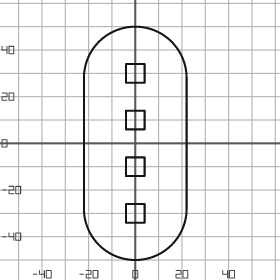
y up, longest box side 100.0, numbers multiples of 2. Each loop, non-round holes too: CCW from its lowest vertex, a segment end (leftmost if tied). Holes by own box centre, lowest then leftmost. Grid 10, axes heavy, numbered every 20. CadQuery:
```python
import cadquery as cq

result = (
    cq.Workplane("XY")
    .moveTo(-22.0, -28.0)
    .threePointArc((0.0, -50.0), (22.0, -28.0))
    .lineTo(22.0, 28.0)
    .threePointArc((0.0, 50.0), (-22.0, 28.0))
    .close()
    .moveTo(-4.0, -34.0)
    .lineTo(4.0, -34.0)
    .lineTo(4.0, -26.0)
    .lineTo(-4.0, -26.0)
    .close()
    .moveTo(-4.0, -14.0)
    .lineTo(4.0, -14.0)
    .lineTo(4.0, -6.0)
    .lineTo(-4.0, -6.0)
    .close()
    .moveTo(-4.0, 6.0)
    .lineTo(4.0, 6.0)
    .lineTo(4.0, 14.0)
    .lineTo(-4.0, 14.0)
    .close()
    .moveTo(-4.0, 26.0)
    .lineTo(4.0, 26.0)
    .lineTo(4.0, 34.0)
    .lineTo(-4.0, 34.0)
    .close()
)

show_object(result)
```